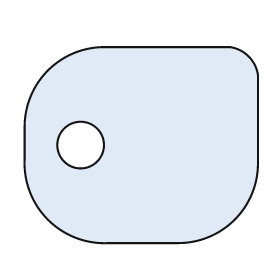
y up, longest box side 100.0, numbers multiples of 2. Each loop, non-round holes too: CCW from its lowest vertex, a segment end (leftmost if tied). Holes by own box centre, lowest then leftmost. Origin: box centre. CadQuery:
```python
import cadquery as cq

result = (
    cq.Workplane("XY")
    .moveTo(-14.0, -42.0)
    .lineTo(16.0, -42.0)
    .threePointArc((40.0, -32.0), (50.0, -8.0))
    .lineTo(50.0, 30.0)
    .threePointArc((46.0, 38.0), (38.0, 42.0))
    .lineTo(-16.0, 42.0)
    .threePointArc((-40.0, 32.0), (-50.0, 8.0))
    .lineTo(-50.0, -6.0)
    .threePointArc((-40.0, -32.0), (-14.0, -42.0))
    .close()
    .moveTo(-26.0, 0.0)
    .circle(10.0)
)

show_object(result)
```